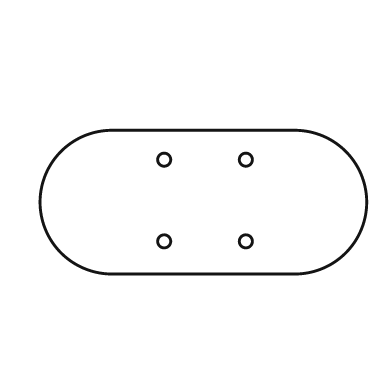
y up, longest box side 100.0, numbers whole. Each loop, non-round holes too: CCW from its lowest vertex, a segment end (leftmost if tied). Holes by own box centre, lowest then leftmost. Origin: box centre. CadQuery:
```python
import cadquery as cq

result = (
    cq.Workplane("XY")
    .moveTo(-28.0, -22.0)
    .lineTo(28.0, -22.0)
    .threePointArc((50.0, 0.0), (28.0, 22.0))
    .lineTo(-28.0, 22.0)
    .threePointArc((-50.0, 0.0), (-28.0, -22.0))
    .close()
    .moveTo(-12.0, -12.0)
    .circle(2.0)
    .moveTo(13.0, -12.0)
    .circle(2.0)
    .moveTo(-12.0, 13.0)
    .circle(2.0)
    .moveTo(13.0, 13.0)
    .circle(2.0)
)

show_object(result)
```